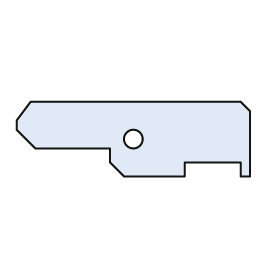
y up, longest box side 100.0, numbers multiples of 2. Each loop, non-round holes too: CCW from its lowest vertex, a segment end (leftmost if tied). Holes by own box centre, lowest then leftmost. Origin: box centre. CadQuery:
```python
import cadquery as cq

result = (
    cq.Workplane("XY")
    .moveTo(-4.0, -16.0)
    .lineTo(22.0, -16.0)
    .lineTo(22.0, -10.0)
    .lineTo(46.0, -10.0)
    .lineTo(46.0, -16.0)
    .lineTo(50.0, -16.0)
    .lineTo(50.0, 12.0)
    .lineTo(46.0, 16.0)
    .lineTo(-44.0, 16.0)
    .lineTo(-50.0, 8.0)
    .lineTo(-50.0, 4.0)
    .lineTo(-42.0, -4.0)
    .lineTo(-10.0, -4.0)
    .lineTo(-10.0, -10.0)
    .close()
    .moveTo(0.0, 0.0)
    .circle(4.0)
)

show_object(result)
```